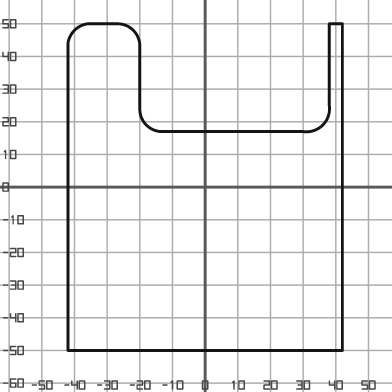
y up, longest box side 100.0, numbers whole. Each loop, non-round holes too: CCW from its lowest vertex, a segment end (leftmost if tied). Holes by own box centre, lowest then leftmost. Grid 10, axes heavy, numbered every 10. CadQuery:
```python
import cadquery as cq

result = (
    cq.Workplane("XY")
    .moveTo(-42.0, -50.0)
    .lineTo(42.0, -50.0)
    .lineTo(42.0, 50.0)
    .lineTo(38.0, 50.0)
    .lineTo(38.0, 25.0)
    .threePointArc((36.0, 19.0), (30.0, 17.0))
    .lineTo(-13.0, 17.0)
    .threePointArc((-18.0, 19.0), (-20.0, 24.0))
    .lineTo(-20.0, 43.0)
    .threePointArc((-22.0, 48.0), (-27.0, 50.0))
    .lineTo(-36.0, 50.0)
    .threePointArc((-40.0, 48.0), (-42.0, 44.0))
    .close()
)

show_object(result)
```